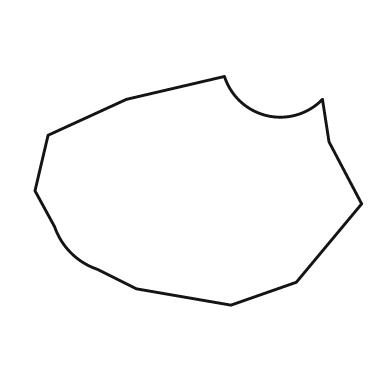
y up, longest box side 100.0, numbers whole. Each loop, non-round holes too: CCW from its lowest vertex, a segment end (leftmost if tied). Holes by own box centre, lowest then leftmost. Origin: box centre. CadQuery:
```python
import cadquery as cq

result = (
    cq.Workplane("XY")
    .moveTo(10.0, -35.0)
    .lineTo(30.0, -28.0)
    .lineTo(50.0, -4.0)
    .lineTo(40.0, 15.0)
    .lineTo(38.0, 28.0)
    .threePointArc((21.0, 23.0), (8.0, 35.0))
    .lineTo(-22.0, 28.0)
    .lineTo(-46.0, 17.0)
    .lineTo(-50.0, 0.0)
    .lineTo(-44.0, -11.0)
    .threePointArc((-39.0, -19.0), (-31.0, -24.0))
    .lineTo(-19.0, -30.0)
    .close()
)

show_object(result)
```